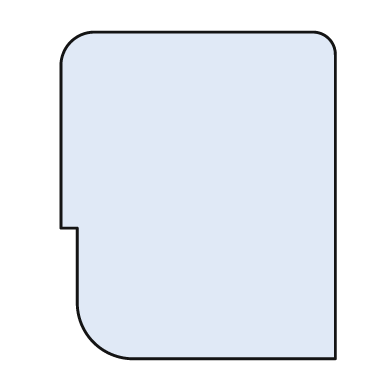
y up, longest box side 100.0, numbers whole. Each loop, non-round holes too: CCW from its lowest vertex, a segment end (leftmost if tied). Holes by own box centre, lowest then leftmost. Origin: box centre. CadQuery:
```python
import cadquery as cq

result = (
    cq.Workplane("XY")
    .moveTo(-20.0, -50.0)
    .lineTo(42.0, -50.0)
    .lineTo(42.0, 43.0)
    .threePointArc((40.0, 48.0), (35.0, 50.0))
    .lineTo(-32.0, 50.0)
    .threePointArc((-39.0, 47.0), (-42.0, 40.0))
    .lineTo(-42.0, -10.0)
    .lineTo(-37.0, -10.0)
    .lineTo(-37.0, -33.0)
    .threePointArc((-32.0, -45.0), (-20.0, -50.0))
    .close()
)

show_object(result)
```